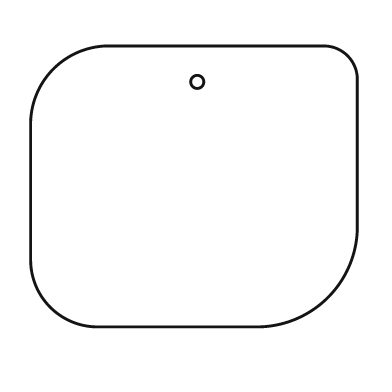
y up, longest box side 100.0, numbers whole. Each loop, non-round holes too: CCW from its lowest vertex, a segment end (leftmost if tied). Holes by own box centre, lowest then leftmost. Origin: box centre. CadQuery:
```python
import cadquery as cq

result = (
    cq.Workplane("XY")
    .moveTo(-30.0, -43.0)
    .lineTo(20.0, -43.0)
    .threePointArc((41.0, -34.0), (50.0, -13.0))
    .lineTo(50.0, 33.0)
    .threePointArc((47.0, 40.0), (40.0, 43.0))
    .lineTo(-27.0, 43.0)
    .threePointArc((-43.0, 36.0), (-50.0, 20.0))
    .lineTo(-50.0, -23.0)
    .threePointArc((-44.0, -37.0), (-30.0, -43.0))
    .close()
    .moveTo(1.0, 32.0)
    .circle(2.0)
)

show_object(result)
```